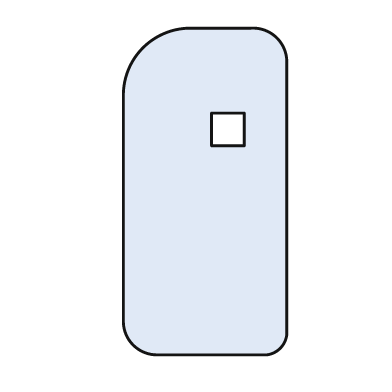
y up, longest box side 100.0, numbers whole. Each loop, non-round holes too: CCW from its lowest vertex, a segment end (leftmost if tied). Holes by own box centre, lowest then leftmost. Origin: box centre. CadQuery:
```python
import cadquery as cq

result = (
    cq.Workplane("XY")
    .moveTo(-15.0, -50.0)
    .lineTo(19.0, -50.0)
    .threePointArc((23.0, -48.0), (25.0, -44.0))
    .lineTo(25.0, 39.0)
    .threePointArc((22.0, 47.0), (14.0, 50.0))
    .lineTo(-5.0, 50.0)
    .threePointArc((-19.0, 44.0), (-25.0, 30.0))
    .lineTo(-25.0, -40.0)
    .threePointArc((-22.0, -47.0), (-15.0, -50.0))
    .close()
    .moveTo(2.0, 14.0)
    .lineTo(12.0, 14.0)
    .lineTo(12.0, 24.0)
    .lineTo(2.0, 24.0)
    .close()
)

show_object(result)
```